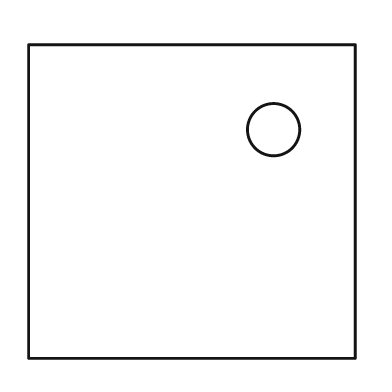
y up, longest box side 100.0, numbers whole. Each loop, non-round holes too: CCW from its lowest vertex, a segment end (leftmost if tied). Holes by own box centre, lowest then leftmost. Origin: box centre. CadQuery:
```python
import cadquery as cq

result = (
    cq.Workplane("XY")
    .moveTo(-50.0, -48.0)
    .lineTo(50.0, -48.0)
    .lineTo(50.0, 48.0)
    .lineTo(-50.0, 48.0)
    .close()
    .moveTo(25.0, 22.0)
    .circle(8.0)
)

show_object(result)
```